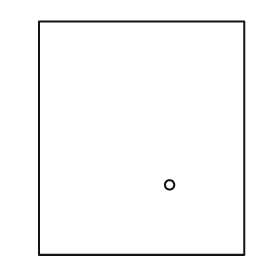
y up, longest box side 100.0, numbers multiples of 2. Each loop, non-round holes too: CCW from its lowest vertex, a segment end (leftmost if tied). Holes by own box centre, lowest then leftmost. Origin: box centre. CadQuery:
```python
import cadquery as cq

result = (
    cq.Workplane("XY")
    .moveTo(-44.0, -50.0)
    .lineTo(44.0, -50.0)
    .lineTo(44.0, 50.0)
    .lineTo(-44.0, 50.0)
    .close()
    .moveTo(12.0, -20.0)
    .circle(2.0)
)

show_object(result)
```